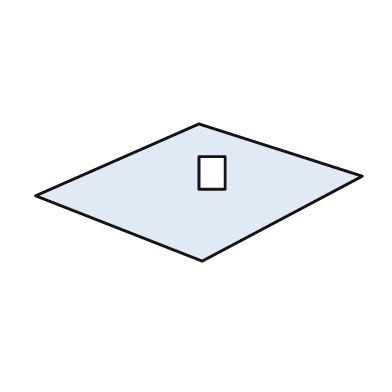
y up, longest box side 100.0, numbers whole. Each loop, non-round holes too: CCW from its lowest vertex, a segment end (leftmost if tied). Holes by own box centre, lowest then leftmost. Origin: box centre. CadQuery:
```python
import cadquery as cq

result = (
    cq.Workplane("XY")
    .moveTo(1.0, -21.0)
    .lineTo(50.0, 5.0)
    .lineTo(0.0, 21.0)
    .lineTo(-50.0, -1.0)
    .close()
    .moveTo(0.0, 1.0)
    .lineTo(8.0, 1.0)
    .lineTo(8.0, 11.0)
    .lineTo(0.0, 11.0)
    .close()
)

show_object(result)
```